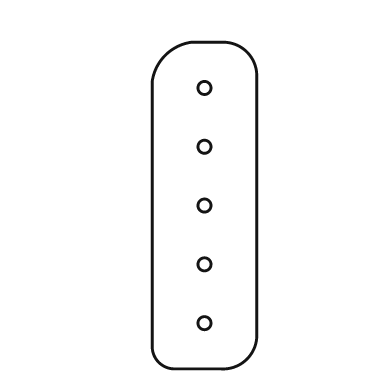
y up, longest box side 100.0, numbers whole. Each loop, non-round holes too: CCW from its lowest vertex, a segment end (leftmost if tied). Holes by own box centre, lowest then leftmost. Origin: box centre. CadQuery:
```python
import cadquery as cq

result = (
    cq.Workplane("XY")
    .moveTo(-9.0, -50.0)
    .lineTo(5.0, -50.0)
    .threePointArc((13.0, -47.0), (16.0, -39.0))
    .lineTo(16.0, 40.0)
    .threePointArc((13.0, 47.0), (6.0, 50.0))
    .lineTo(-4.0, 50.0)
    .threePointArc((-12.0, 46.0), (-16.0, 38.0))
    .lineTo(-16.0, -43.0)
    .threePointArc((-14.0, -48.0), (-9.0, -50.0))
    .close()
    .moveTo(0.0, -36.0)
    .circle(2.0)
    .moveTo(0.0, -18.0)
    .circle(2.0)
    .moveTo(0.0, 0.0)
    .circle(2.0)
    .moveTo(0.0, 18.0)
    .circle(2.0)
    .moveTo(0.0, 36.0)
    .circle(2.0)
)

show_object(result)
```